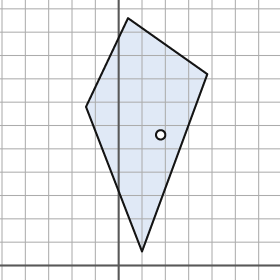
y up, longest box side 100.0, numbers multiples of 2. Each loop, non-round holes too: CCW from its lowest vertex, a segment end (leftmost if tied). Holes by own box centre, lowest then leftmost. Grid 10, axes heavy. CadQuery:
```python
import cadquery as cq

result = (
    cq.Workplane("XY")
    .moveTo(10.0, 6.0)
    .lineTo(38.0, 82.0)
    .lineTo(4.0, 106.0)
    .lineTo(-14.0, 68.0)
    .close()
    .moveTo(18.0, 56.0)
    .circle(2.0)
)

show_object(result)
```